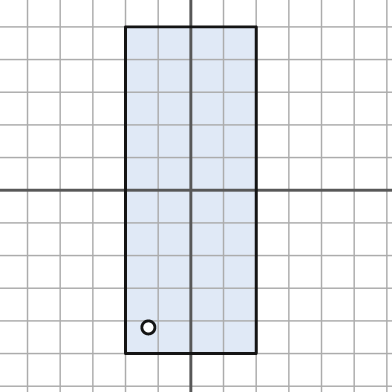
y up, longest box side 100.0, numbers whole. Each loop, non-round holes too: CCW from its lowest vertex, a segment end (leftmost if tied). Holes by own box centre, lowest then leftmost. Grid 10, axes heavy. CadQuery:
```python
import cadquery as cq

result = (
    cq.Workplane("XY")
    .moveTo(-20.0, -50.0)
    .lineTo(20.0, -50.0)
    .lineTo(20.0, 50.0)
    .lineTo(-20.0, 50.0)
    .close()
    .moveTo(-13.0, -42.0)
    .circle(2.0)
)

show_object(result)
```